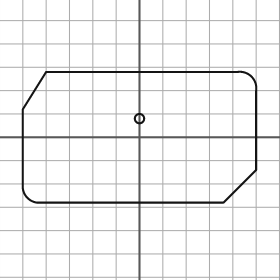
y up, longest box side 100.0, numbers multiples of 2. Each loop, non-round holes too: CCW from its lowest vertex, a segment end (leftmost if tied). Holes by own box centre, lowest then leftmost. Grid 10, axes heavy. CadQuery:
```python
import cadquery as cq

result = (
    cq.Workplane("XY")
    .moveTo(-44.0, -28.0)
    .lineTo(36.0, -28.0)
    .lineTo(50.0, -14.0)
    .lineTo(50.0, 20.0)
    .threePointArc((48.0, 26.0), (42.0, 28.0))
    .lineTo(-40.0, 28.0)
    .lineTo(-50.0, 12.0)
    .lineTo(-50.0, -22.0)
    .threePointArc((-48.0, -26.0), (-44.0, -28.0))
    .close()
    .moveTo(0.0, 8.0)
    .circle(2.0)
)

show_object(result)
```